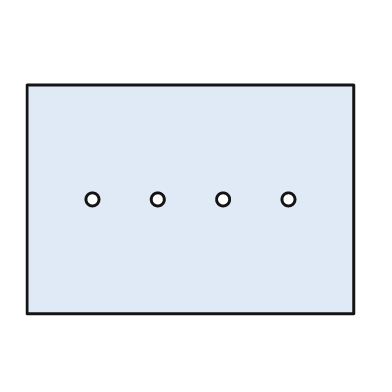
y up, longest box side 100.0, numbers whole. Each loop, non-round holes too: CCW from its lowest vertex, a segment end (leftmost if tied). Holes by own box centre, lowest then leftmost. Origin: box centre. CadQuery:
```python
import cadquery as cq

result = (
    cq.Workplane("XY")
    .moveTo(-50.0, -35.0)
    .lineTo(50.0, -35.0)
    .lineTo(50.0, 35.0)
    .lineTo(-50.0, 35.0)
    .close()
    .moveTo(-30.0, 0.0)
    .circle(2.0)
    .moveTo(-10.0, 0.0)
    .circle(2.0)
    .moveTo(10.0, 0.0)
    .circle(2.0)
    .moveTo(30.0, 0.0)
    .circle(2.0)
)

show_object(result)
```